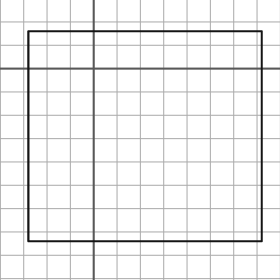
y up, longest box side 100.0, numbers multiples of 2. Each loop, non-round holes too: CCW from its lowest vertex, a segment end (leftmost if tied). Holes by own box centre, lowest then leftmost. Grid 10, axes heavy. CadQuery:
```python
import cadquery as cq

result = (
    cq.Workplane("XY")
    .moveTo(-28.0, -74.0)
    .lineTo(72.0, -74.0)
    .lineTo(72.0, 16.0)
    .lineTo(-28.0, 16.0)
    .close()
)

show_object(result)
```